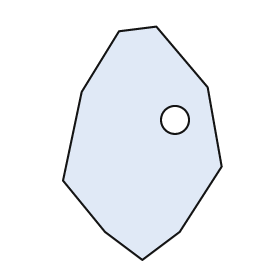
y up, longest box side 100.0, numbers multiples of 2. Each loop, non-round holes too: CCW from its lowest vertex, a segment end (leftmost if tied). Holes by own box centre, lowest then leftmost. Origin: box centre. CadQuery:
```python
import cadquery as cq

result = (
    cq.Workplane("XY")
    .moveTo(0.0, -50.0)
    .lineTo(16.0, -38.0)
    .lineTo(34.0, -10.0)
    .lineTo(28.0, 24.0)
    .lineTo(6.0, 50.0)
    .lineTo(-10.0, 48.0)
    .lineTo(-26.0, 22.0)
    .lineTo(-34.0, -16.0)
    .lineTo(-16.0, -38.0)
    .close()
    .moveTo(14.0, 10.0)
    .circle(6.0)
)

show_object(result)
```